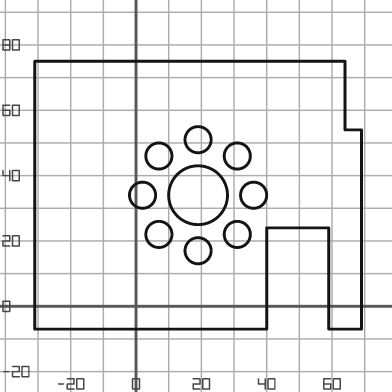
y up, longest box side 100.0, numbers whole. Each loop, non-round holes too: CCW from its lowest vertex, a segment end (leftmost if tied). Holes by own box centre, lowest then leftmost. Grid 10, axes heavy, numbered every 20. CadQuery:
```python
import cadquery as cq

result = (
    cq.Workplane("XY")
    .moveTo(-31.0, -7.0)
    .lineTo(40.0, -7.0)
    .lineTo(40.0, 24.0)
    .lineTo(59.0, 24.0)
    .lineTo(59.0, -7.0)
    .lineTo(69.0, -7.0)
    .lineTo(69.0, 54.0)
    .lineTo(64.0, 54.0)
    .lineTo(64.0, 75.0)
    .lineTo(-31.0, 75.0)
    .close()
    .moveTo(19.0, 17.0)
    .circle(4.0)
    .moveTo(7.0, 22.0)
    .circle(4.0)
    .moveTo(31.0, 22.0)
    .circle(4.0)
    .moveTo(2.0, 34.0)
    .circle(4.0)
    .moveTo(19.0, 34.0)
    .circle(9.0)
    .moveTo(36.0, 34.0)
    .circle(4.0)
    .moveTo(7.0, 46.0)
    .circle(4.0)
    .moveTo(31.0, 46.0)
    .circle(4.0)
    .moveTo(19.0, 51.0)
    .circle(4.0)
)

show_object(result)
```